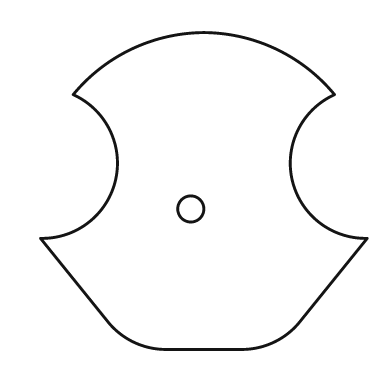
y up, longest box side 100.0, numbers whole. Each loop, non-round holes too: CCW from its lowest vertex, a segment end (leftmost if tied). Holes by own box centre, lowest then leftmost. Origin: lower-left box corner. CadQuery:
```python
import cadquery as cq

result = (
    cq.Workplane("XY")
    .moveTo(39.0, 0.0)
    .lineTo(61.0, 0.0)
    .threePointArc((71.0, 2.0), (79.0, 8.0))
    .lineTo(100.0, 34.0)
    .threePointArc((77.0, 52.0), (90.0, 78.0))
    .threePointArc((72.0, 92.0), (50.0, 97.0))
    .threePointArc((28.0, 92.0), (10.0, 78.0))
    .threePointArc((23.0, 52.0), (0.0, 34.0))
    .lineTo(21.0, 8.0)
    .threePointArc((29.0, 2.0), (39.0, 0.0))
    .close()
    .moveTo(46.0, 43.0)
    .circle(4.0)
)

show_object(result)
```